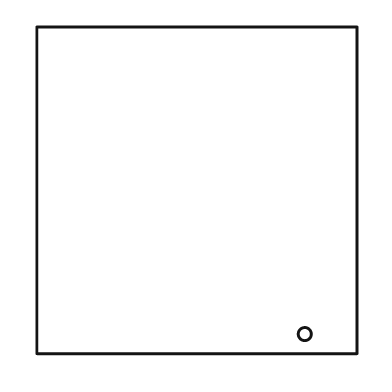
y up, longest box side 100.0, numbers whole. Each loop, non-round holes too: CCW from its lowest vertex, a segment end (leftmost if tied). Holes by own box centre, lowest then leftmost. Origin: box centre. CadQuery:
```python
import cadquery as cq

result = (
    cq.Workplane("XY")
    .moveTo(-49.0, -50.0)
    .lineTo(49.0, -50.0)
    .lineTo(49.0, 50.0)
    .lineTo(-49.0, 50.0)
    .close()
    .moveTo(33.0, -44.0)
    .circle(2.0)
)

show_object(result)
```